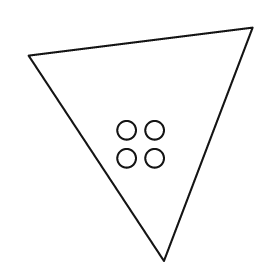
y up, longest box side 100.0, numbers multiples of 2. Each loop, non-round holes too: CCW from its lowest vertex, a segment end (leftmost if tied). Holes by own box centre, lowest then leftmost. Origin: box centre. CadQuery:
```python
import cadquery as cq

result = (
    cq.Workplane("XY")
    .moveTo(10.0, -50.0)
    .lineTo(48.0, 50.0)
    .lineTo(-48.0, 38.0)
    .close()
    .moveTo(-6.0, -6.0)
    .circle(4.0)
    .moveTo(6.0, -6.0)
    .circle(4.0)
    .moveTo(-6.0, 6.0)
    .circle(4.0)
    .moveTo(6.0, 6.0)
    .circle(4.0)
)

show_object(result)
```